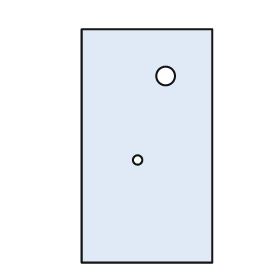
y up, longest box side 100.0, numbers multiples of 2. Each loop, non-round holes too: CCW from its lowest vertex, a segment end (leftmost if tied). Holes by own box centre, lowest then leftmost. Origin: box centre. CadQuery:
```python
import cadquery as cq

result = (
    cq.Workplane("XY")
    .moveTo(-28.0, -50.0)
    .lineTo(28.0, -50.0)
    .lineTo(28.0, 50.0)
    .lineTo(-28.0, 50.0)
    .close()
    .moveTo(-4.0, -6.0)
    .circle(2.0)
    .moveTo(8.0, 30.0)
    .circle(4.0)
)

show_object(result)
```